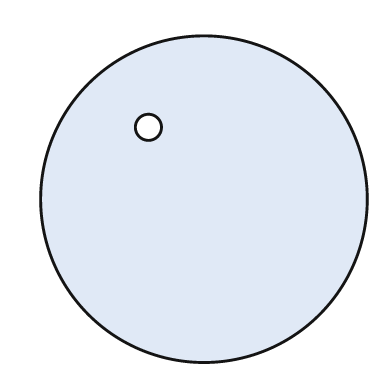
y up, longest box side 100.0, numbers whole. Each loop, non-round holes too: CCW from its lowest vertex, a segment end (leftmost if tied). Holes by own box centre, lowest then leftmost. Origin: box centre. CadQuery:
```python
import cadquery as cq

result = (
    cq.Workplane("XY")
    .moveTo(0.0, 0.0)
    .circle(50.0)
    .moveTo(-17.0, 22.0)
    .circle(4.0)
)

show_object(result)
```